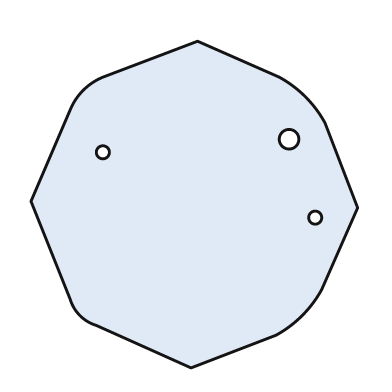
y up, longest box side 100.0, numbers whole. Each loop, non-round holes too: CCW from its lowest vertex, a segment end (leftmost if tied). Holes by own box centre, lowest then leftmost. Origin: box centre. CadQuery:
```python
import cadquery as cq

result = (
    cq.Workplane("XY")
    .moveTo(-1.0, -50.0)
    .lineTo(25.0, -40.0)
    .threePointArc((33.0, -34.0), (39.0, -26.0))
    .lineTo(50.0, -1.0)
    .lineTo(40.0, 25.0)
    .threePointArc((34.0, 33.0), (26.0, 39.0))
    .lineTo(1.0, 50.0)
    .lineTo(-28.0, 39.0)
    .threePointArc((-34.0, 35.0), (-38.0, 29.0))
    .lineTo(-50.0, 1.0)
    .lineTo(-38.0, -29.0)
    .threePointArc((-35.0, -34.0), (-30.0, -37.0))
    .close()
    .moveTo(37.0, -4.0)
    .circle(2.0)
    .moveTo(-28.0, 16.0)
    .circle(2.0)
    .moveTo(29.0, 20.0)
    .circle(3.0)
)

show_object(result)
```